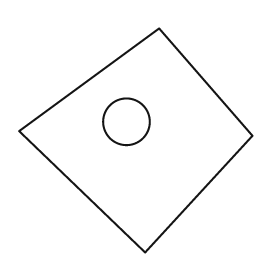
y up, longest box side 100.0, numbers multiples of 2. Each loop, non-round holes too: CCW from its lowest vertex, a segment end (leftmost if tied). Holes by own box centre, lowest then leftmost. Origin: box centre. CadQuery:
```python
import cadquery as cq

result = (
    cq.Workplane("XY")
    .moveTo(4.0, -48.0)
    .lineTo(50.0, 2.0)
    .lineTo(10.0, 48.0)
    .lineTo(-50.0, 4.0)
    .close()
    .moveTo(-4.0, 8.0)
    .circle(10.0)
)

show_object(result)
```